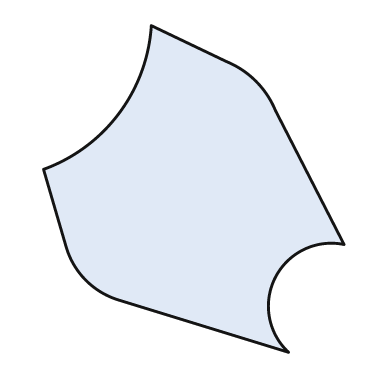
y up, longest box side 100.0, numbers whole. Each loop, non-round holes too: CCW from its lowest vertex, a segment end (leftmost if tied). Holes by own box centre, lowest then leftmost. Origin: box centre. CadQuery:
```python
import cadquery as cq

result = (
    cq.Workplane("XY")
    .moveTo(29.0, -50.0)
    .threePointArc((25.0, -27.0), (46.0, -17.0))
    .lineTo(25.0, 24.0)
    .threePointArc((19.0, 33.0), (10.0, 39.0))
    .lineTo(-13.0, 50.0)
    .threePointArc((-23.0, 23.0), (-46.0, 6.0))
    .lineTo(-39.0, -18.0)
    .threePointArc((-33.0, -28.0), (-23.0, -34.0))
    .close()
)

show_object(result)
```